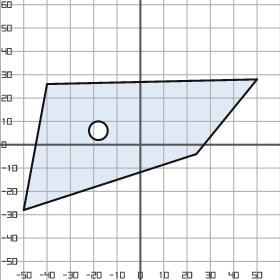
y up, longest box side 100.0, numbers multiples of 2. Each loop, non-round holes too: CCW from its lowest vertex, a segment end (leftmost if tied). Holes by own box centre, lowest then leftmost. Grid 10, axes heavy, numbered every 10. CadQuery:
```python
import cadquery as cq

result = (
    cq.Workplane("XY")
    .moveTo(-50.0, -28.0)
    .lineTo(24.0, -4.0)
    .lineTo(50.0, 28.0)
    .lineTo(-40.0, 26.0)
    .close()
    .moveTo(-18.0, 6.0)
    .circle(4.0)
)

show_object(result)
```